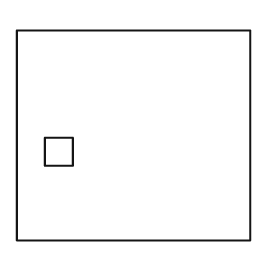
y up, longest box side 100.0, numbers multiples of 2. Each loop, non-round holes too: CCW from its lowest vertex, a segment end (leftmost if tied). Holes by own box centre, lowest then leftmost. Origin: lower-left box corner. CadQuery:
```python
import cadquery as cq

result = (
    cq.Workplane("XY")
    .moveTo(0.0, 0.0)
    .lineTo(100.0, 0.0)
    .lineTo(100.0, 90.0)
    .lineTo(0.0, 90.0)
    .close()
    .moveTo(12.0, 32.0)
    .lineTo(24.0, 32.0)
    .lineTo(24.0, 44.0)
    .lineTo(12.0, 44.0)
    .close()
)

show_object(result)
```